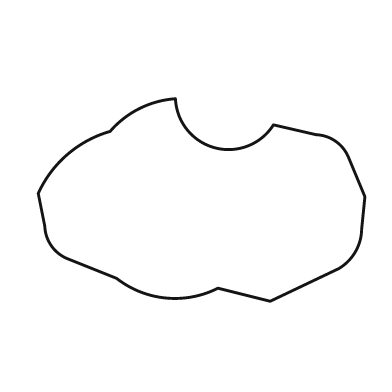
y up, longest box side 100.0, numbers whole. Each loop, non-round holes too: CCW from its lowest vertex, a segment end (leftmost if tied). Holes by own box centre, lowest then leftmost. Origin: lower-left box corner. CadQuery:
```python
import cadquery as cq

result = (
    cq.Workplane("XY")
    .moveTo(71.0, 0.0)
    .lineTo(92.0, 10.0)
    .threePointArc((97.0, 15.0), (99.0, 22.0))
    .lineTo(100.0, 32.0)
    .lineTo(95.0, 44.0)
    .threePointArc((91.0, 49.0), (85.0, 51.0))
    .lineTo(72.0, 54.0)
    .threePointArc((54.0, 47.0), (42.0, 62.0))
    .threePointArc((31.0, 59.0), (22.0, 52.0))
    .threePointArc((9.0, 45.0), (0.0, 33.0))
    .lineTo(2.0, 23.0)
    .threePointArc((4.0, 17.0), (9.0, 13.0))
    .lineTo(24.0, 7.0)
    .threePointArc((39.0, 1.0), (55.0, 4.0))
    .close()
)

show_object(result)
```